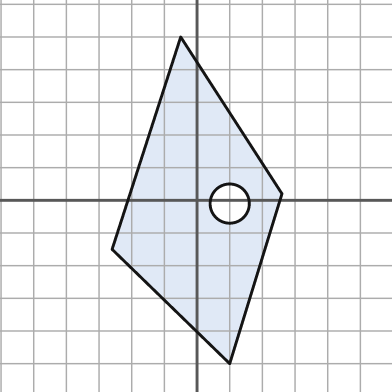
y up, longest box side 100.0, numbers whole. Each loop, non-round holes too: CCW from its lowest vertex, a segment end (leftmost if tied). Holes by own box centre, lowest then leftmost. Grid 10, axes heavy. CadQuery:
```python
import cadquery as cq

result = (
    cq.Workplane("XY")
    .moveTo(10.0, -50.0)
    .lineTo(26.0, 2.0)
    .lineTo(-5.0, 50.0)
    .lineTo(-26.0, -15.0)
    .close()
    .moveTo(10.0, -1.0)
    .circle(6.0)
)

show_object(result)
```